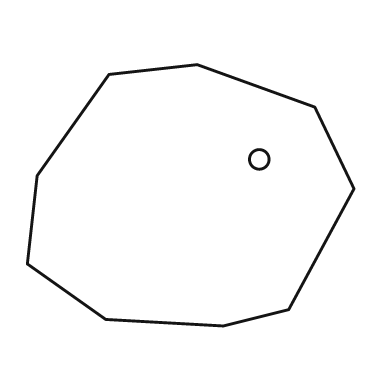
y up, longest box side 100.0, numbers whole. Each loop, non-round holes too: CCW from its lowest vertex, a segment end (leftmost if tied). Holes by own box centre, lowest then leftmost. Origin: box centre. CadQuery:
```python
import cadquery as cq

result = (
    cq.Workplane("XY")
    .moveTo(10.0, -40.0)
    .lineTo(30.0, -35.0)
    .lineTo(50.0, 2.0)
    .lineTo(38.0, 27.0)
    .lineTo(2.0, 40.0)
    .lineTo(-25.0, 37.0)
    .lineTo(-47.0, 6.0)
    .lineTo(-50.0, -21.0)
    .lineTo(-26.0, -38.0)
    .close()
    .moveTo(21.0, 11.0)
    .circle(3.0)
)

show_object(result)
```